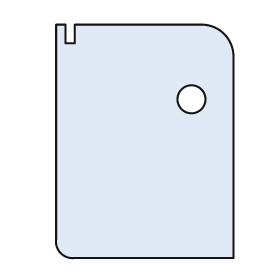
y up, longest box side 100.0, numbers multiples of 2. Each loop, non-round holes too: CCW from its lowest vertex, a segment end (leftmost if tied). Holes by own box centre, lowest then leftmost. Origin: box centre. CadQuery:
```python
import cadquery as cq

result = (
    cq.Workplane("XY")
    .moveTo(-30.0, -50.0)
    .lineTo(38.0, -50.0)
    .lineTo(38.0, 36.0)
    .threePointArc((34.0, 46.0), (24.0, 50.0))
    .lineTo(-30.0, 50.0)
    .lineTo(-30.0, 42.0)
    .lineTo(-34.0, 42.0)
    .lineTo(-34.0, 50.0)
    .lineTo(-38.0, 50.0)
    .lineTo(-38.0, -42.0)
    .threePointArc((-36.0, -48.0), (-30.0, -50.0))
    .close()
    .moveTo(20.0, 18.0)
    .circle(6.0)
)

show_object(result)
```